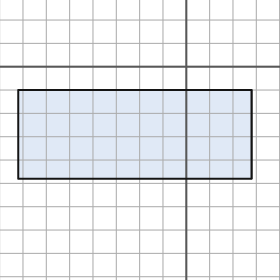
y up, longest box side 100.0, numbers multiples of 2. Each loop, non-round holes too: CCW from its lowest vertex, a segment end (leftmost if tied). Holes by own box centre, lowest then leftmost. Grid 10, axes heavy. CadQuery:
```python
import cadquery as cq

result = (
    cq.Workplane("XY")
    .moveTo(-72.0, -48.0)
    .lineTo(28.0, -48.0)
    .lineTo(28.0, -10.0)
    .lineTo(-72.0, -10.0)
    .close()
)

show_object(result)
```